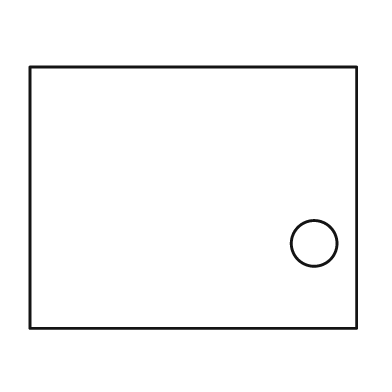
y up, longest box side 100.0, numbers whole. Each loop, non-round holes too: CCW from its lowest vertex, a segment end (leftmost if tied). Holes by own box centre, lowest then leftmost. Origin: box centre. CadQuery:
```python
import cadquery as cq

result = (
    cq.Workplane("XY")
    .moveTo(-50.0, -40.0)
    .lineTo(50.0, -40.0)
    .lineTo(50.0, 40.0)
    .lineTo(-50.0, 40.0)
    .close()
    .moveTo(37.0, -14.0)
    .circle(7.0)
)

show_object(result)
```